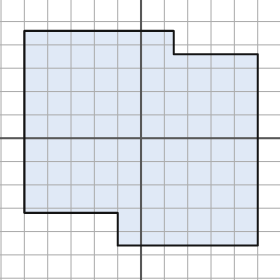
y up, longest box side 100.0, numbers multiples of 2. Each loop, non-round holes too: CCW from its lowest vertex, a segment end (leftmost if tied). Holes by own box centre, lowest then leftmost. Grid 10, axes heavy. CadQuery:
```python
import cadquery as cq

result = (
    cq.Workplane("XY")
    .moveTo(-10.0, -46.0)
    .lineTo(50.0, -46.0)
    .lineTo(50.0, 36.0)
    .lineTo(14.0, 36.0)
    .lineTo(14.0, 46.0)
    .lineTo(-50.0, 46.0)
    .lineTo(-50.0, -32.0)
    .lineTo(-10.0, -32.0)
    .close()
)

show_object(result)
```